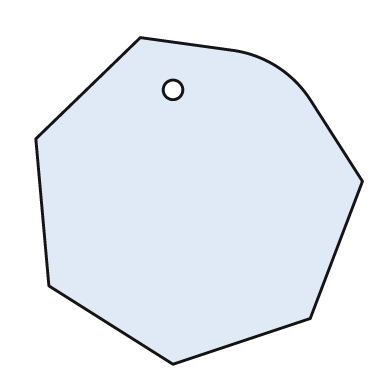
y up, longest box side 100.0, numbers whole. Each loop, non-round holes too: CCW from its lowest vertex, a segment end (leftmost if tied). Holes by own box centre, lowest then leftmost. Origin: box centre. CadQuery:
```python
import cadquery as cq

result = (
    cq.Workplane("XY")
    .moveTo(-8.0, -50.0)
    .lineTo(34.0, -36.0)
    .lineTo(50.0, 6.0)
    .lineTo(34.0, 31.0)
    .threePointArc((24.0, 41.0), (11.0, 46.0))
    .lineTo(-18.0, 50.0)
    .lineTo(-50.0, 19.0)
    .lineTo(-46.0, -26.0)
    .close()
    .moveTo(-8.0, 34.0)
    .circle(3.0)
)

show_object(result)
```